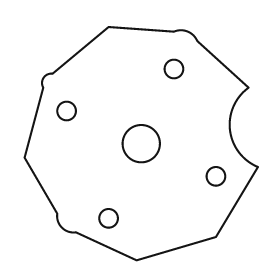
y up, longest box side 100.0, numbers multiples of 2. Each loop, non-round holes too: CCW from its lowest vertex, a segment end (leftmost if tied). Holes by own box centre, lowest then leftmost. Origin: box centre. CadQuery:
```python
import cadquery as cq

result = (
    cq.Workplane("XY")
    .moveTo(-2.0, -50.0)
    .lineTo(32.0, -40.0)
    .lineTo(50.0, -10.0)
    .threePointArc((38.0, 6.0), (46.0, 24.0))
    .lineTo(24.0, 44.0)
    .threePointArc((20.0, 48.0), (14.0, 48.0))
    .lineTo(-14.0, 50.0)
    .lineTo(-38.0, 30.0)
    .threePointArc((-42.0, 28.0), (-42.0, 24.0))
    .lineTo(-50.0, -6.0)
    .lineTo(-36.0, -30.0)
    .threePointArc((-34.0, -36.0), (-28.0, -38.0))
    .close()
    .moveTo(-14.0, -32.0)
    .circle(4.0)
    .moveTo(32.0, -14.0)
    .circle(4.0)
    .moveTo(0.0, 0.0)
    .circle(8.0)
    .moveTo(-32.0, 14.0)
    .circle(4.0)
    .moveTo(14.0, 32.0)
    .circle(4.0)
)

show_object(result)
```